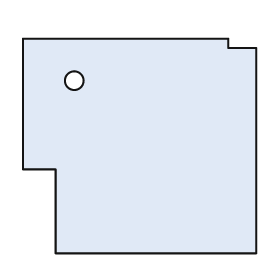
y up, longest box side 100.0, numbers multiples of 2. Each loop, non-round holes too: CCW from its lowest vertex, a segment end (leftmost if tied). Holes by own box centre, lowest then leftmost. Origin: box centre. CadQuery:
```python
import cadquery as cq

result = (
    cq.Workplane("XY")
    .moveTo(-36.0, -46.0)
    .lineTo(50.0, -46.0)
    .lineTo(50.0, 42.0)
    .lineTo(38.0, 42.0)
    .lineTo(38.0, 46.0)
    .lineTo(-50.0, 46.0)
    .lineTo(-50.0, -10.0)
    .lineTo(-36.0, -10.0)
    .close()
    .moveTo(-28.0, 28.0)
    .circle(4.0)
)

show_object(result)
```